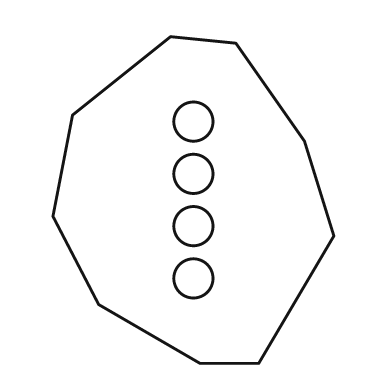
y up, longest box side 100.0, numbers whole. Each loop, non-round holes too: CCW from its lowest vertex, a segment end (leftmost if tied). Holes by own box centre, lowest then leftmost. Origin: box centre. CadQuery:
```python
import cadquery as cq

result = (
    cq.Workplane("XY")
    .moveTo(2.0, -50.0)
    .lineTo(20.0, -50.0)
    .lineTo(43.0, -11.0)
    .lineTo(34.0, 18.0)
    .lineTo(13.0, 48.0)
    .lineTo(-7.0, 50.0)
    .lineTo(-37.0, 26.0)
    .lineTo(-43.0, -5.0)
    .lineTo(-29.0, -32.0)
    .close()
    .moveTo(0.0, -24.0)
    .circle(6.0)
    .moveTo(0.0, -8.0)
    .circle(6.0)
    .moveTo(0.0, 8.0)
    .circle(6.0)
    .moveTo(0.0, 24.0)
    .circle(6.0)
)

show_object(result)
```